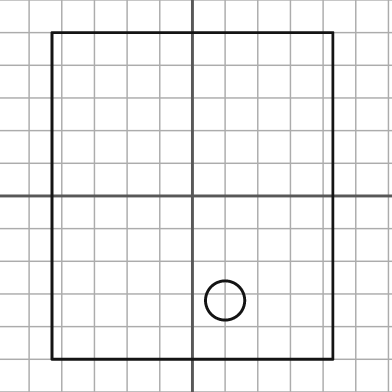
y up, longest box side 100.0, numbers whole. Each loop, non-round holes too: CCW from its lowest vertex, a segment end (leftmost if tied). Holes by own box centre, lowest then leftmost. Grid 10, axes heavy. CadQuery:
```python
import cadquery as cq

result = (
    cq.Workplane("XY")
    .moveTo(-43.0, -50.0)
    .lineTo(43.0, -50.0)
    .lineTo(43.0, 50.0)
    .lineTo(-43.0, 50.0)
    .close()
    .moveTo(10.0, -32.0)
    .circle(6.0)
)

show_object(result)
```